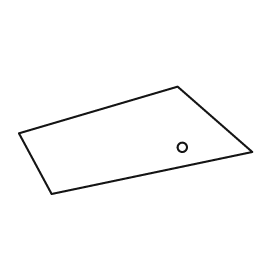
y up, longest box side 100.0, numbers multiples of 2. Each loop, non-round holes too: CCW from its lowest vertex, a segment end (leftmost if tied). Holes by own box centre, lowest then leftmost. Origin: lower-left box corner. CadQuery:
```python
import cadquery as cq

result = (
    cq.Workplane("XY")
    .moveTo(14.0, 0.0)
    .lineTo(100.0, 18.0)
    .lineTo(68.0, 46.0)
    .lineTo(0.0, 26.0)
    .close()
    .moveTo(70.0, 20.0)
    .circle(2.0)
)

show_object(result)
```